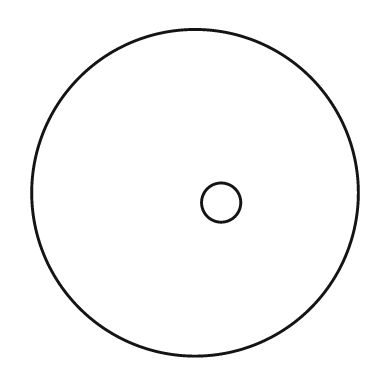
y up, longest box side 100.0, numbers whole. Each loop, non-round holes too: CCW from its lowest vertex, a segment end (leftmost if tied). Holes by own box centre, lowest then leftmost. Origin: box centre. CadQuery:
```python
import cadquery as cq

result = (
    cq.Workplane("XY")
    .moveTo(0.0, 0.0)
    .circle(50.0)
    .moveTo(8.0, -3.0)
    .circle(6.0)
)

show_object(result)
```